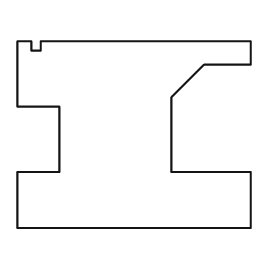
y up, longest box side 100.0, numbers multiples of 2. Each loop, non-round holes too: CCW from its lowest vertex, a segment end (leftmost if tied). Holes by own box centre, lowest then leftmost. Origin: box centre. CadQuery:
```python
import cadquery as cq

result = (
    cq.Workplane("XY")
    .moveTo(-50.0, -40.0)
    .lineTo(50.0, -40.0)
    .lineTo(50.0, -16.0)
    .lineTo(16.0, -16.0)
    .lineTo(16.0, 16.0)
    .lineTo(30.0, 30.0)
    .lineTo(50.0, 30.0)
    .lineTo(50.0, 40.0)
    .lineTo(-40.0, 40.0)
    .lineTo(-40.0, 36.0)
    .lineTo(-44.0, 36.0)
    .lineTo(-44.0, 40.0)
    .lineTo(-50.0, 40.0)
    .lineTo(-50.0, 12.0)
    .lineTo(-32.0, 12.0)
    .lineTo(-32.0, -16.0)
    .lineTo(-50.0, -16.0)
    .close()
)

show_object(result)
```